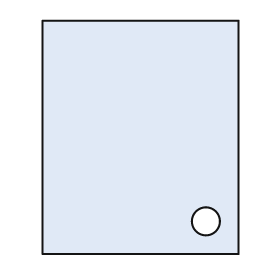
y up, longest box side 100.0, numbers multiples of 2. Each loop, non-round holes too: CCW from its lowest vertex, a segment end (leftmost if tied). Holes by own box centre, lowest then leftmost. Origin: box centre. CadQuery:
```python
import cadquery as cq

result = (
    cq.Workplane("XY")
    .moveTo(-42.0, -50.0)
    .lineTo(42.0, -50.0)
    .lineTo(42.0, 50.0)
    .lineTo(-42.0, 50.0)
    .close()
    .moveTo(28.0, -36.0)
    .circle(6.0)
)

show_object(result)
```